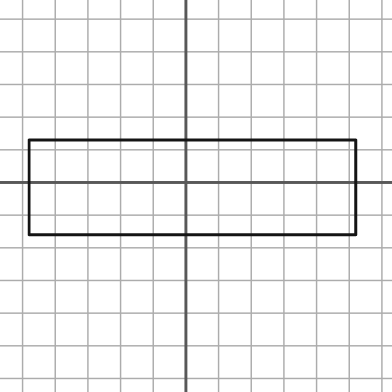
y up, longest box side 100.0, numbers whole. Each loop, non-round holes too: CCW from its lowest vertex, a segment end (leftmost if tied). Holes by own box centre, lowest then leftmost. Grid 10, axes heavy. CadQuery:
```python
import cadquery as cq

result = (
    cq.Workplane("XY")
    .moveTo(-48.0, -16.0)
    .lineTo(52.0, -16.0)
    .lineTo(52.0, 13.0)
    .lineTo(-48.0, 13.0)
    .close()
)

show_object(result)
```